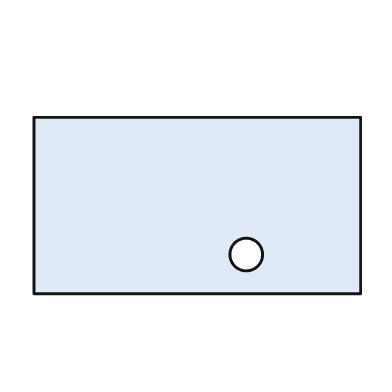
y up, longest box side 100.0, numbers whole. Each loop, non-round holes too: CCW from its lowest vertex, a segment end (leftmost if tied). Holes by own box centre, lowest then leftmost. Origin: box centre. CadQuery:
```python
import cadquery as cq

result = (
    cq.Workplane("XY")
    .moveTo(-50.0, -27.0)
    .lineTo(50.0, -27.0)
    .lineTo(50.0, 27.0)
    .lineTo(-50.0, 27.0)
    .close()
    .moveTo(15.0, -15.0)
    .circle(5.0)
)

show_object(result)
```